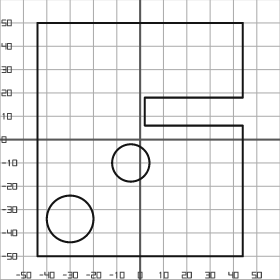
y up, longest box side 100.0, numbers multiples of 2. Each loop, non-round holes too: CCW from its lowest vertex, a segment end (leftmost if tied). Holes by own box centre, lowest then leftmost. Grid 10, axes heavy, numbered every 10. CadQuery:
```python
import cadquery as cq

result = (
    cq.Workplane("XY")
    .moveTo(-44.0, -50.0)
    .lineTo(44.0, -50.0)
    .lineTo(44.0, 6.0)
    .lineTo(2.0, 6.0)
    .lineTo(2.0, 18.0)
    .lineTo(44.0, 18.0)
    .lineTo(44.0, 50.0)
    .lineTo(-44.0, 50.0)
    .close()
    .moveTo(-30.0, -34.0)
    .circle(10.0)
    .moveTo(-4.0, -10.0)
    .circle(8.0)
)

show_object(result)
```